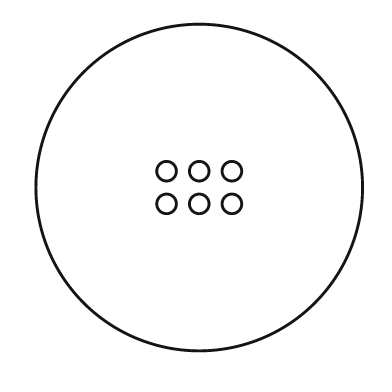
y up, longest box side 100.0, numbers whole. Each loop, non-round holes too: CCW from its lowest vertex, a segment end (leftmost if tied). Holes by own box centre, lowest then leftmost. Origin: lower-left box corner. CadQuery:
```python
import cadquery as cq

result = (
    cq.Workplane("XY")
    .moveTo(50.0, 50.0)
    .circle(50.0)
    .moveTo(40.0, 45.0)
    .circle(3.0)
    .moveTo(50.0, 45.0)
    .circle(3.0)
    .moveTo(60.0, 45.0)
    .circle(3.0)
    .moveTo(40.0, 55.0)
    .circle(3.0)
    .moveTo(50.0, 55.0)
    .circle(3.0)
    .moveTo(60.0, 55.0)
    .circle(3.0)
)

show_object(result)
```